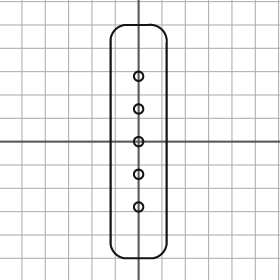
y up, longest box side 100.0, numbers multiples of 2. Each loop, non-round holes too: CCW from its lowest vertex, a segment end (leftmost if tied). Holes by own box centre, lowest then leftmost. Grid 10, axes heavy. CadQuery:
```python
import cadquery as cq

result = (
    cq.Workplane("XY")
    .moveTo(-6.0, -50.0)
    .lineTo(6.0, -50.0)
    .threePointArc((10.0, -48.0), (12.0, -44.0))
    .lineTo(12.0, 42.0)
    .threePointArc((10.0, 48.0), (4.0, 50.0))
    .lineTo(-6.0, 50.0)
    .threePointArc((-10.0, 48.0), (-12.0, 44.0))
    .lineTo(-12.0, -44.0)
    .threePointArc((-10.0, -48.0), (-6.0, -50.0))
    .close()
    .moveTo(0.0, -28.0)
    .circle(2.0)
    .moveTo(0.0, -14.0)
    .circle(2.0)
    .moveTo(0.0, 0.0)
    .circle(2.0)
    .moveTo(0.0, 14.0)
    .circle(2.0)
    .moveTo(0.0, 28.0)
    .circle(2.0)
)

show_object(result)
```